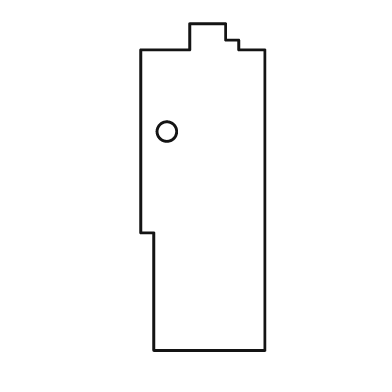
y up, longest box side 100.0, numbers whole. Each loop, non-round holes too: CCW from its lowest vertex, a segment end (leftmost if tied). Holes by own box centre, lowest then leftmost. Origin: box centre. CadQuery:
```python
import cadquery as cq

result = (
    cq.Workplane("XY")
    .moveTo(-15.0, -50.0)
    .lineTo(19.0, -50.0)
    .lineTo(19.0, 42.0)
    .lineTo(11.0, 42.0)
    .lineTo(11.0, 45.0)
    .lineTo(7.0, 45.0)
    .lineTo(7.0, 50.0)
    .lineTo(-4.0, 50.0)
    .lineTo(-4.0, 42.0)
    .lineTo(-19.0, 42.0)
    .lineTo(-19.0, -14.0)
    .lineTo(-15.0, -14.0)
    .close()
    .moveTo(-11.0, 17.0)
    .circle(3.0)
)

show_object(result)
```